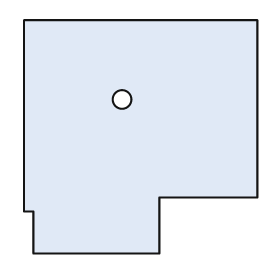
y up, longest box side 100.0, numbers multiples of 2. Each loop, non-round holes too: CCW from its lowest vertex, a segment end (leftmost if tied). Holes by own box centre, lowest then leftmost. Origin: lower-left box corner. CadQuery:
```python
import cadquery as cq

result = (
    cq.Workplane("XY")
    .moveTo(4.0, 0.0)
    .lineTo(58.0, 0.0)
    .lineTo(58.0, 24.0)
    .lineTo(100.0, 24.0)
    .lineTo(100.0, 100.0)
    .lineTo(0.0, 100.0)
    .lineTo(0.0, 18.0)
    .lineTo(4.0, 18.0)
    .close()
    .moveTo(42.0, 66.0)
    .circle(4.0)
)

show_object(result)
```